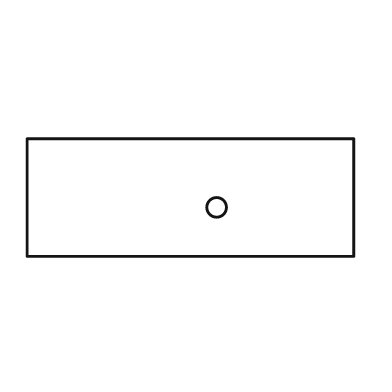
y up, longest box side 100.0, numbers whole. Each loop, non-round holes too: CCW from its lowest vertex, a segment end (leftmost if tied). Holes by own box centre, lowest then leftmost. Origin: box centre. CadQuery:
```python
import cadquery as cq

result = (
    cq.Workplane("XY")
    .moveTo(-50.0, -18.0)
    .lineTo(50.0, -18.0)
    .lineTo(50.0, 18.0)
    .lineTo(-50.0, 18.0)
    .close()
    .moveTo(8.0, -3.0)
    .circle(3.0)
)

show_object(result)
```